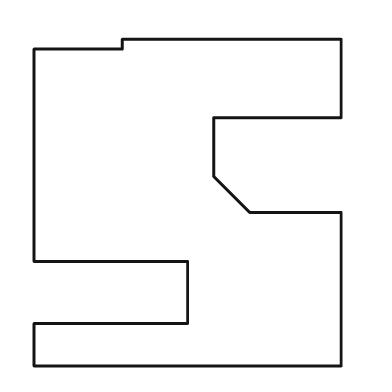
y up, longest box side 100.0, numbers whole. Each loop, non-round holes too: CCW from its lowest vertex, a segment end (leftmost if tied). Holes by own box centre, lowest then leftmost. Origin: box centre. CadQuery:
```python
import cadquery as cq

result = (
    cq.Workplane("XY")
    .moveTo(-47.0, -50.0)
    .lineTo(47.0, -50.0)
    .lineTo(47.0, -3.0)
    .lineTo(19.0, -3.0)
    .lineTo(8.0, 8.0)
    .lineTo(8.0, 26.0)
    .lineTo(47.0, 26.0)
    .lineTo(47.0, 50.0)
    .lineTo(-20.0, 50.0)
    .lineTo(-20.0, 47.0)
    .lineTo(-47.0, 47.0)
    .lineTo(-47.0, -18.0)
    .lineTo(0.0, -18.0)
    .lineTo(0.0, -37.0)
    .lineTo(-47.0, -37.0)
    .close()
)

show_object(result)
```